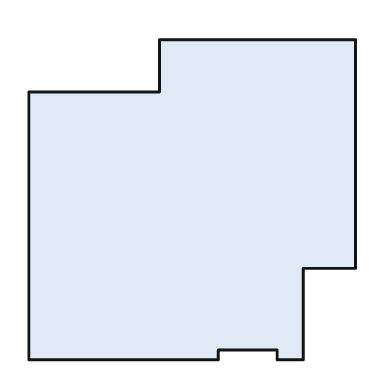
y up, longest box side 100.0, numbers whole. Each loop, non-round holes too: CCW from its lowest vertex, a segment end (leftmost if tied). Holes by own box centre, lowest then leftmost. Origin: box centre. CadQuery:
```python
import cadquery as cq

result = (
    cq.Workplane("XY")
    .moveTo(-50.0, -49.0)
    .lineTo(8.0, -49.0)
    .lineTo(8.0, -46.0)
    .lineTo(26.0, -46.0)
    .lineTo(26.0, -49.0)
    .lineTo(34.0, -49.0)
    .lineTo(34.0, -21.0)
    .lineTo(50.0, -21.0)
    .lineTo(50.0, 49.0)
    .lineTo(-10.0, 49.0)
    .lineTo(-10.0, 33.0)
    .lineTo(-50.0, 33.0)
    .close()
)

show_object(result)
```